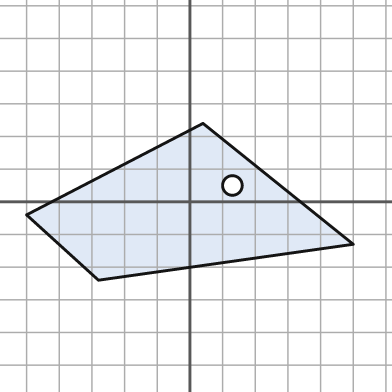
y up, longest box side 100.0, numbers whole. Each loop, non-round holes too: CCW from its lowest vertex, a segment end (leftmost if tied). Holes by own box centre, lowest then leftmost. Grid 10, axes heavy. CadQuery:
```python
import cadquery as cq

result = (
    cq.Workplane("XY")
    .moveTo(-28.0, -24.0)
    .lineTo(50.0, -13.0)
    .lineTo(4.0, 24.0)
    .lineTo(-50.0, -4.0)
    .close()
    .moveTo(13.0, 5.0)
    .circle(3.0)
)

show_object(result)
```